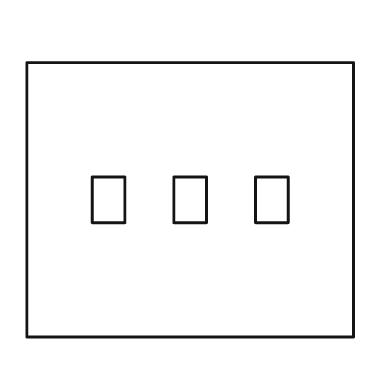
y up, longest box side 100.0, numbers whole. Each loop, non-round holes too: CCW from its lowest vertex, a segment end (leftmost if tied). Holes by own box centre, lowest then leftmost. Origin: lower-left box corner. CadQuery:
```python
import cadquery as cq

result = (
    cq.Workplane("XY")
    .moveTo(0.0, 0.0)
    .lineTo(100.0, 0.0)
    .lineTo(100.0, 84.0)
    .lineTo(0.0, 84.0)
    .close()
    .moveTo(20.0, 35.0)
    .lineTo(30.0, 35.0)
    .lineTo(30.0, 49.0)
    .lineTo(20.0, 49.0)
    .close()
    .moveTo(45.0, 35.0)
    .lineTo(55.0, 35.0)
    .lineTo(55.0, 49.0)
    .lineTo(45.0, 49.0)
    .close()
    .moveTo(70.0, 35.0)
    .lineTo(80.0, 35.0)
    .lineTo(80.0, 49.0)
    .lineTo(70.0, 49.0)
    .close()
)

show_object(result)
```